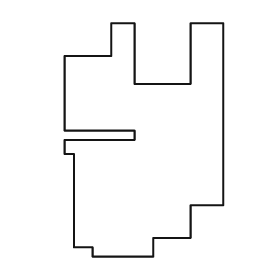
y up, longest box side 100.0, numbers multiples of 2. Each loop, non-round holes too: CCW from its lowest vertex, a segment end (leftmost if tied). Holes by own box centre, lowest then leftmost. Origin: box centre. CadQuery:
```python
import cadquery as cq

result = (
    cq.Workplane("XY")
    .moveTo(-22.0, -50.0)
    .lineTo(4.0, -50.0)
    .lineTo(4.0, -42.0)
    .lineTo(20.0, -42.0)
    .lineTo(20.0, -28.0)
    .lineTo(34.0, -28.0)
    .lineTo(34.0, 50.0)
    .lineTo(20.0, 50.0)
    .lineTo(20.0, 24.0)
    .lineTo(-4.0, 24.0)
    .lineTo(-4.0, 50.0)
    .lineTo(-14.0, 50.0)
    .lineTo(-14.0, 36.0)
    .lineTo(-34.0, 36.0)
    .lineTo(-34.0, 4.0)
    .lineTo(-4.0, 4.0)
    .lineTo(-4.0, 0.0)
    .lineTo(-34.0, 0.0)
    .lineTo(-34.0, -6.0)
    .lineTo(-30.0, -6.0)
    .lineTo(-30.0, -46.0)
    .lineTo(-22.0, -46.0)
    .close()
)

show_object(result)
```